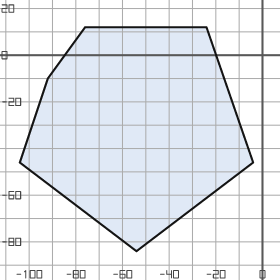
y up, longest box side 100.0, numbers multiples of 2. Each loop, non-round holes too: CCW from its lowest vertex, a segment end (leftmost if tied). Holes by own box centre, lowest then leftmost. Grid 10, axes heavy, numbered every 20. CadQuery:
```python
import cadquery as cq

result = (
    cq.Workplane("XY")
    .moveTo(-54.0, -84.0)
    .lineTo(-4.0, -46.0)
    .lineTo(-24.0, 12.0)
    .lineTo(-76.0, 12.0)
    .lineTo(-92.0, -10.0)
    .lineTo(-104.0, -46.0)
    .close()
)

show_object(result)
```